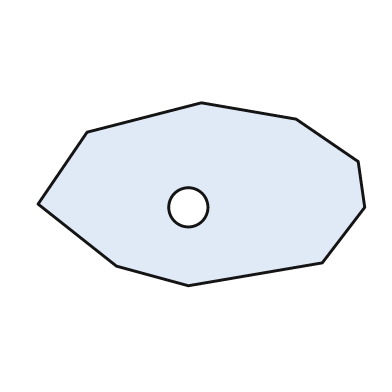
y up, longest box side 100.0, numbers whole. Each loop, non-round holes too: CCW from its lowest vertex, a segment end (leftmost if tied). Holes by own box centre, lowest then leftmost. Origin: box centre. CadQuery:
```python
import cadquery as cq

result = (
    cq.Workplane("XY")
    .moveTo(-4.0, -28.0)
    .lineTo(37.0, -21.0)
    .lineTo(50.0, -4.0)
    .lineTo(48.0, 10.0)
    .lineTo(29.0, 23.0)
    .lineTo(0.0, 28.0)
    .lineTo(-35.0, 19.0)
    .lineTo(-50.0, -3.0)
    .lineTo(-26.0, -22.0)
    .close()
    .moveTo(-4.0, -4.0)
    .circle(6.0)
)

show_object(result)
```